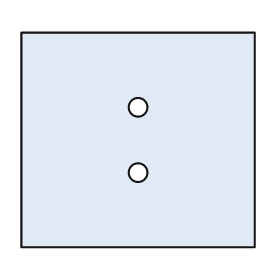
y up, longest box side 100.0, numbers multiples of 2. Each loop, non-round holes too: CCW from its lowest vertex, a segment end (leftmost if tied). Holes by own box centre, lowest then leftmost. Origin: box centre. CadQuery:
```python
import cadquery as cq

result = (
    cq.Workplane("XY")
    .moveTo(-50.0, -46.0)
    .lineTo(50.0, -46.0)
    .lineTo(50.0, 46.0)
    .lineTo(-50.0, 46.0)
    .close()
    .moveTo(0.0, -14.0)
    .circle(4.0)
    .moveTo(0.0, 14.0)
    .circle(4.0)
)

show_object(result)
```